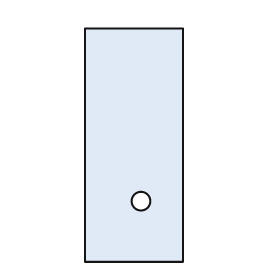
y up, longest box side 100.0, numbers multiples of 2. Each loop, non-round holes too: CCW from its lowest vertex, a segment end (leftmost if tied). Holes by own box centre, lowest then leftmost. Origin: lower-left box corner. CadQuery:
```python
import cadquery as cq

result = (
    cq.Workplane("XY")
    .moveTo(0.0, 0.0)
    .lineTo(42.0, 0.0)
    .lineTo(42.0, 100.0)
    .lineTo(0.0, 100.0)
    .close()
    .moveTo(24.0, 26.0)
    .circle(4.0)
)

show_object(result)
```